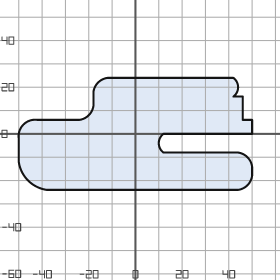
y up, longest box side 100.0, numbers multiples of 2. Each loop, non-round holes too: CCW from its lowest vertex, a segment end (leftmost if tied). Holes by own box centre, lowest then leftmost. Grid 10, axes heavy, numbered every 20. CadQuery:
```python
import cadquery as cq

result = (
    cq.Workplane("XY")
    .moveTo(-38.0, -24.0)
    .lineTo(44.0, -24.0)
    .threePointArc((48.0, -22.0), (50.0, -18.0))
    .lineTo(50.0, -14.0)
    .threePointArc((48.0, -10.0), (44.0, -8.0))
    .lineTo(12.0, -8.0)
    .threePointArc((10.0, -4.0), (12.0, 0.0))
    .lineTo(50.0, 0.0)
    .lineTo(50.0, 6.0)
    .lineTo(46.0, 6.0)
    .lineTo(46.0, 16.0)
    .lineTo(42.0, 16.0)
    .threePointArc((44.0, 20.0), (42.0, 24.0))
    .lineTo(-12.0, 24.0)
    .threePointArc((-16.0, 22.0), (-18.0, 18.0))
    .lineTo(-18.0, 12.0)
    .threePointArc((-20.0, 8.0), (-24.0, 6.0))
    .lineTo(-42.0, 6.0)
    .threePointArc((-48.0, 4.0), (-50.0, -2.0))
    .lineTo(-50.0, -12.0)
    .threePointArc((-46.0, -20.0), (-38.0, -24.0))
    .close()
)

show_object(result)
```